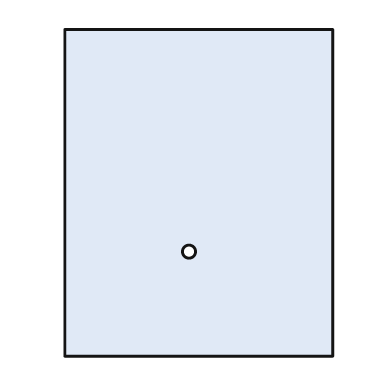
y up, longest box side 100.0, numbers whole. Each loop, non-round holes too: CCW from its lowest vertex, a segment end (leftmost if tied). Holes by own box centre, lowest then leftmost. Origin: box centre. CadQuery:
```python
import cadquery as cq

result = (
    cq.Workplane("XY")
    .moveTo(-41.0, -50.0)
    .lineTo(41.0, -50.0)
    .lineTo(41.0, 50.0)
    .lineTo(-41.0, 50.0)
    .close()
    .moveTo(-3.0, -18.0)
    .circle(2.0)
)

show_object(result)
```